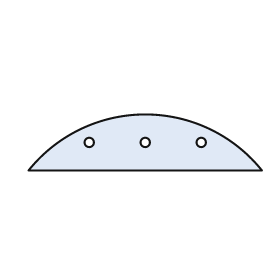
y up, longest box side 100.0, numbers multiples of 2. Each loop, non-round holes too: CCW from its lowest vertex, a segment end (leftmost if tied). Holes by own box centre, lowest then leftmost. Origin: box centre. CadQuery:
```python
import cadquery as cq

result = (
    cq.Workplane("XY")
    .moveTo(-50.0, -12.0)
    .lineTo(50.0, -12.0)
    .threePointArc((0.0, 12.0), (-50.0, -12.0))
    .close()
    .moveTo(-24.0, 0.0)
    .circle(2.0)
    .moveTo(0.0, 0.0)
    .circle(2.0)
    .moveTo(24.0, 0.0)
    .circle(2.0)
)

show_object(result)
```